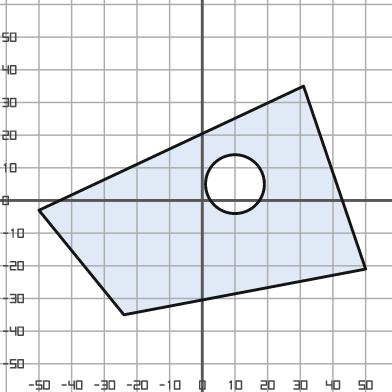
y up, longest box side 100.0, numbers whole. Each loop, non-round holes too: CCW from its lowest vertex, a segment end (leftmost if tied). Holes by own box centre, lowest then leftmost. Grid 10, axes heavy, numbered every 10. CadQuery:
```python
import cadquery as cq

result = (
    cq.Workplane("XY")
    .moveTo(-24.0, -35.0)
    .lineTo(50.0, -21.0)
    .lineTo(31.0, 35.0)
    .lineTo(-50.0, -3.0)
    .close()
    .moveTo(10.0, 5.0)
    .circle(9.0)
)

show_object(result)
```